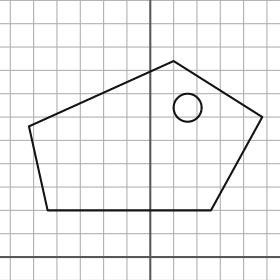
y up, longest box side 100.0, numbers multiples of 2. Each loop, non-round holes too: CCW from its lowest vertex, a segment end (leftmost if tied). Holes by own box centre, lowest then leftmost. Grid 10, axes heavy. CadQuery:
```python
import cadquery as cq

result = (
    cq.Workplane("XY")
    .moveTo(-44.0, 20.0)
    .lineTo(26.0, 20.0)
    .lineTo(48.0, 60.0)
    .lineTo(10.0, 84.0)
    .lineTo(-52.0, 56.0)
    .close()
    .moveTo(16.0, 64.0)
    .circle(6.0)
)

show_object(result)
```